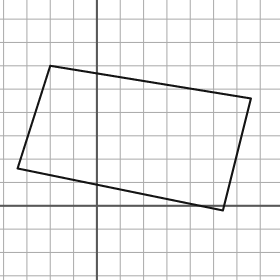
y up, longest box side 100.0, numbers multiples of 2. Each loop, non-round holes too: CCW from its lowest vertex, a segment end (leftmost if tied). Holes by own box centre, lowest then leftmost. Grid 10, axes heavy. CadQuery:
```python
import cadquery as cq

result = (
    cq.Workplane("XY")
    .moveTo(54.0, -2.0)
    .lineTo(66.0, 46.0)
    .lineTo(-20.0, 60.0)
    .lineTo(-34.0, 16.0)
    .close()
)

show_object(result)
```